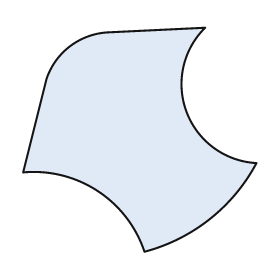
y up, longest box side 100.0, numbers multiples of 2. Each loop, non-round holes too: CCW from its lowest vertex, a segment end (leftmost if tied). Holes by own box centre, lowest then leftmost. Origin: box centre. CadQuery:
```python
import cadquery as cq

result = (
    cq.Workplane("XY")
    .moveTo(2.0, -48.0)
    .threePointArc((30.0, -34.0), (50.0, -10.0))
    .threePointArc((20.0, 12.0), (28.0, 48.0))
    .lineTo(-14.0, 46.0)
    .threePointArc((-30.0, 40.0), (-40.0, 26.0))
    .lineTo(-50.0, -14.0)
    .threePointArc((-18.0, -22.0), (2.0, -48.0))
    .close()
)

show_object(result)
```